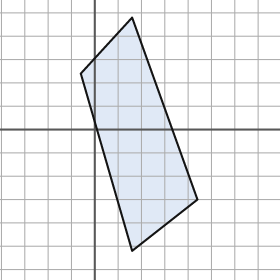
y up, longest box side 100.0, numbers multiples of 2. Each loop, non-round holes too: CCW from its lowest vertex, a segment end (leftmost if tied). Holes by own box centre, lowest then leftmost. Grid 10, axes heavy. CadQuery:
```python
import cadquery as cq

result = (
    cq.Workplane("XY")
    .moveTo(16.0, -52.0)
    .lineTo(44.0, -30.0)
    .lineTo(16.0, 48.0)
    .lineTo(-6.0, 24.0)
    .close()
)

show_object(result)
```